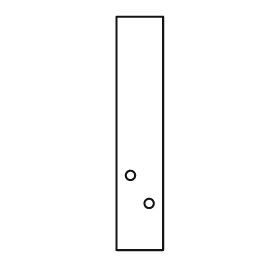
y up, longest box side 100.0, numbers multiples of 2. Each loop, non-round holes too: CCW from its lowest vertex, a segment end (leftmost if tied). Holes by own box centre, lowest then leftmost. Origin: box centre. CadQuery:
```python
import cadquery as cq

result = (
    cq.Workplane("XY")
    .moveTo(-10.0, -50.0)
    .lineTo(10.0, -50.0)
    .lineTo(10.0, 50.0)
    .lineTo(-10.0, 50.0)
    .close()
    .moveTo(4.0, -30.0)
    .circle(2.0)
    .moveTo(-4.0, -18.0)
    .circle(2.0)
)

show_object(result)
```